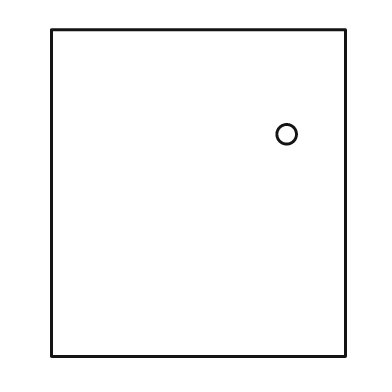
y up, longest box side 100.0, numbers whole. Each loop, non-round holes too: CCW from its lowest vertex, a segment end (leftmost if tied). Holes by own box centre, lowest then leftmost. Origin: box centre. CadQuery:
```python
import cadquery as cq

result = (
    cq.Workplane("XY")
    .moveTo(-45.0, -50.0)
    .lineTo(45.0, -50.0)
    .lineTo(45.0, 50.0)
    .lineTo(-45.0, 50.0)
    .close()
    .moveTo(27.0, 18.0)
    .circle(3.0)
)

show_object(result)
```